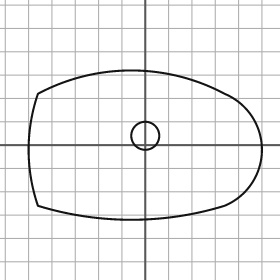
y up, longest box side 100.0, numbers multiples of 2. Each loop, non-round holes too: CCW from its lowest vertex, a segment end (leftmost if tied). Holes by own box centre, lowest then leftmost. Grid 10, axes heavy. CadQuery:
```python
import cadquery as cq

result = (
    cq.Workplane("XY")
    .moveTo(-46.0, -26.0)
    .threePointArc((-6.0, -32.0), (34.0, -26.0))
    .threePointArc((50.0, -2.0), (34.0, 22.0))
    .threePointArc((-6.0, 32.0), (-46.0, 22.0))
    .threePointArc((-50.0, -2.0), (-46.0, -26.0))
    .close()
    .moveTo(0.0, 4.0)
    .circle(6.0)
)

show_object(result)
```